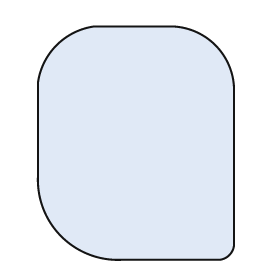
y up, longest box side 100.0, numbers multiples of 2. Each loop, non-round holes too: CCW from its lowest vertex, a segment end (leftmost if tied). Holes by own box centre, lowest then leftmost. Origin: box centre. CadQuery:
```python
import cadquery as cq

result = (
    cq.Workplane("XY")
    .moveTo(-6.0, -50.0)
    .lineTo(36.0, -50.0)
    .threePointArc((40.0, -48.0), (42.0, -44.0))
    .lineTo(42.0, 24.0)
    .threePointArc((34.0, 42.0), (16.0, 50.0))
    .lineTo(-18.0, 50.0)
    .threePointArc((-34.0, 42.0), (-42.0, 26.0))
    .lineTo(-42.0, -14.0)
    .threePointArc((-32.0, -40.0), (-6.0, -50.0))
    .close()
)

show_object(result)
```